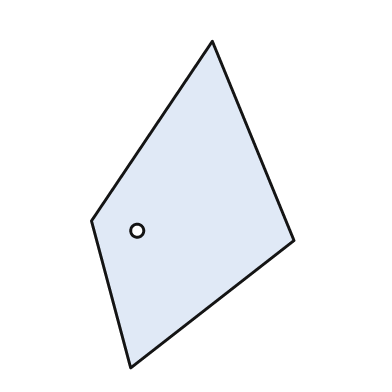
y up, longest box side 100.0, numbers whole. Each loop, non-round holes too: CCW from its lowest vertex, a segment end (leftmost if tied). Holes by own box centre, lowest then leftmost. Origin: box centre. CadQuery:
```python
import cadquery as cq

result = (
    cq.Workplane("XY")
    .moveTo(-19.0, -50.0)
    .lineTo(31.0, -11.0)
    .lineTo(6.0, 50.0)
    .lineTo(-31.0, -5.0)
    .close()
    .moveTo(-17.0, -8.0)
    .circle(2.0)
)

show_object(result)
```